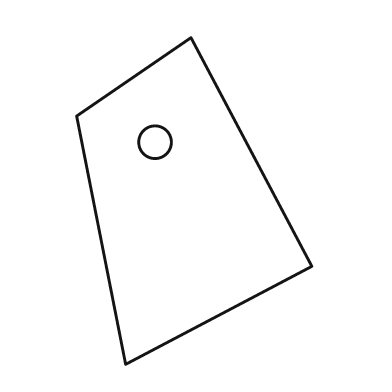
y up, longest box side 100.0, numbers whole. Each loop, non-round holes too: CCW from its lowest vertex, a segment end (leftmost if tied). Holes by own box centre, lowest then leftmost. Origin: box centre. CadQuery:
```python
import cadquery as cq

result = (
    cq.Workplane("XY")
    .moveTo(-21.0, -50.0)
    .lineTo(36.0, -20.0)
    .lineTo(-1.0, 50.0)
    .lineTo(-36.0, 26.0)
    .close()
    .moveTo(-12.0, 18.0)
    .circle(5.0)
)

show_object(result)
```